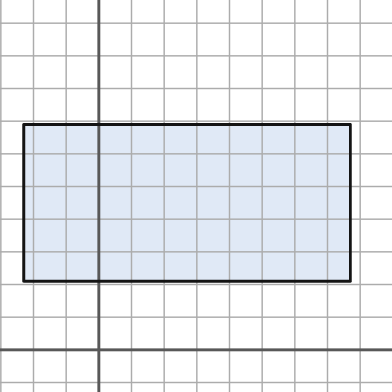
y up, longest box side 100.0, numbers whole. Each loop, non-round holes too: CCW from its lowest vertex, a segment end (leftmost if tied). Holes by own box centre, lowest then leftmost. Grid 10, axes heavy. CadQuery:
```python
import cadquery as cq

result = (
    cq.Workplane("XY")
    .moveTo(-23.0, 21.0)
    .lineTo(77.0, 21.0)
    .lineTo(77.0, 69.0)
    .lineTo(-23.0, 69.0)
    .close()
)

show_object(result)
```